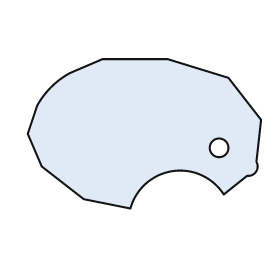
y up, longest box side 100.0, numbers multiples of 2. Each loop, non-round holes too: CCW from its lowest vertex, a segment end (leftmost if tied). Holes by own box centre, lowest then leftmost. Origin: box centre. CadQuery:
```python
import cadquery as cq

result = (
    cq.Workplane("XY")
    .moveTo(-6.0, -32.0)
    .threePointArc((12.0, -16.0), (34.0, -26.0))
    .lineTo(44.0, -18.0)
    .threePointArc((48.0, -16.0), (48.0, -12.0))
    .lineTo(50.0, 6.0)
    .lineTo(36.0, 24.0)
    .lineTo(10.0, 32.0)
    .lineTo(-18.0, 32.0)
    .lineTo(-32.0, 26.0)
    .threePointArc((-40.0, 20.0), (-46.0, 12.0))
    .lineTo(-50.0, 0.0)
    .lineTo(-44.0, -14.0)
    .lineTo(-26.0, -28.0)
    .close()
    .moveTo(32.0, -6.0)
    .circle(4.0)
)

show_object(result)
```